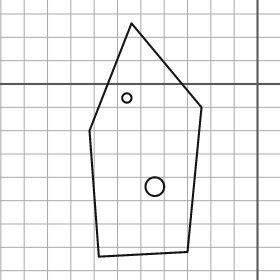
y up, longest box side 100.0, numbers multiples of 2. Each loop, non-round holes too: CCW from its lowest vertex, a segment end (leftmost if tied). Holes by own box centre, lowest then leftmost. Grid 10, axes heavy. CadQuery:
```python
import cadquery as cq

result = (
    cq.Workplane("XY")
    .moveTo(-68.0, -74.0)
    .lineTo(-30.0, -72.0)
    .lineTo(-24.0, -10.0)
    .lineTo(-54.0, 26.0)
    .lineTo(-72.0, -20.0)
    .close()
    .moveTo(-44.0, -44.0)
    .circle(4.0)
    .moveTo(-56.0, -6.0)
    .circle(2.0)
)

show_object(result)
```